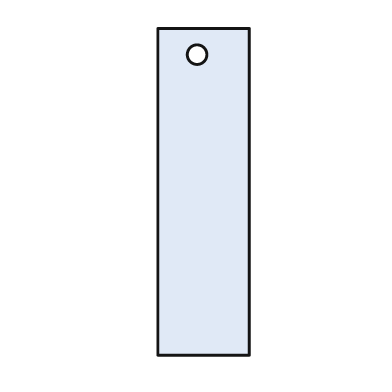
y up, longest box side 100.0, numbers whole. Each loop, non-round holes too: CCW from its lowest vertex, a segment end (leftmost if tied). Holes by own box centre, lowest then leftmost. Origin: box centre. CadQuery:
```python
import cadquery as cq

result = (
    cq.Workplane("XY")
    .moveTo(-14.0, -50.0)
    .lineTo(14.0, -50.0)
    .lineTo(14.0, 50.0)
    .lineTo(-14.0, 50.0)
    .close()
    .moveTo(-2.0, 42.0)
    .circle(3.0)
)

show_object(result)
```